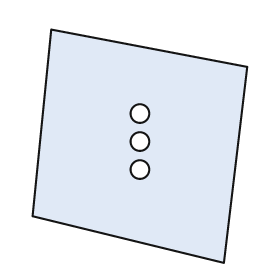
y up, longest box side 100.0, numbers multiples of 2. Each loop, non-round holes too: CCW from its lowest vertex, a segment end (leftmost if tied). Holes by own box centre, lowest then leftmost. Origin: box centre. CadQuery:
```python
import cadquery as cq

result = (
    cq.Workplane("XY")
    .moveTo(36.0, -50.0)
    .lineTo(46.0, 34.0)
    .lineTo(-38.0, 50.0)
    .lineTo(-46.0, -30.0)
    .close()
    .moveTo(0.0, -10.0)
    .circle(4.0)
    .moveTo(0.0, 2.0)
    .circle(4.0)
    .moveTo(0.0, 14.0)
    .circle(4.0)
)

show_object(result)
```